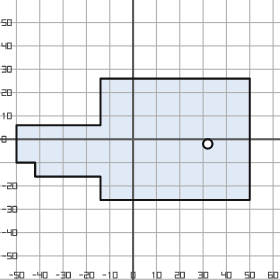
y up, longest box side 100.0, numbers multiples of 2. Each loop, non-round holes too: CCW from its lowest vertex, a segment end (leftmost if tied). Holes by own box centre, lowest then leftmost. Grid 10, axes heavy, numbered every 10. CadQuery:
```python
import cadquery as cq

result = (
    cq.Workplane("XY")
    .moveTo(-14.0, -26.0)
    .lineTo(50.0, -26.0)
    .lineTo(50.0, 26.0)
    .lineTo(-14.0, 26.0)
    .lineTo(-14.0, 6.0)
    .lineTo(-50.0, 6.0)
    .lineTo(-50.0, -10.0)
    .lineTo(-42.0, -10.0)
    .lineTo(-42.0, -16.0)
    .lineTo(-14.0, -16.0)
    .close()
    .moveTo(32.0, -2.0)
    .circle(2.0)
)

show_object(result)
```